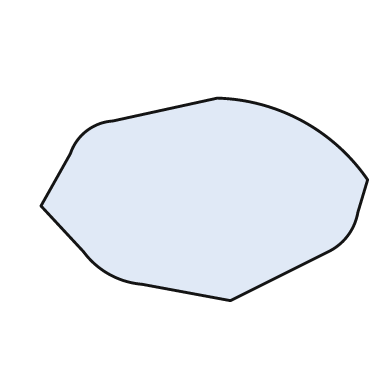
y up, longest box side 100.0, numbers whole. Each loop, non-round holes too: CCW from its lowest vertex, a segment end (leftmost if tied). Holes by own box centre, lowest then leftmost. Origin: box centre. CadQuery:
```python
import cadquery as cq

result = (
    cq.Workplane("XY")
    .moveTo(8.0, -31.0)
    .lineTo(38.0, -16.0)
    .threePointArc((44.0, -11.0), (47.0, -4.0))
    .lineTo(50.0, 6.0)
    .threePointArc((30.0, 24.0), (4.0, 31.0))
    .lineTo(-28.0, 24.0)
    .threePointArc((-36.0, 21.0), (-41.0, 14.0))
    .lineTo(-50.0, -2.0)
    .lineTo(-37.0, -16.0)
    .threePointArc((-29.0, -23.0), (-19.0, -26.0))
    .close()
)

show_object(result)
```